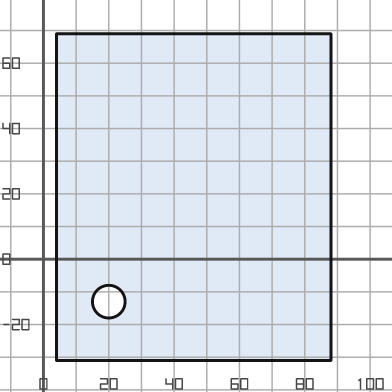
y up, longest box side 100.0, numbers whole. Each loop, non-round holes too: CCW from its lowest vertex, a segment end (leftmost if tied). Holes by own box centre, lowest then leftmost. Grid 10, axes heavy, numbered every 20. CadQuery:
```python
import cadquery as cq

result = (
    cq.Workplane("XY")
    .moveTo(4.0, -31.0)
    .lineTo(88.0, -31.0)
    .lineTo(88.0, 69.0)
    .lineTo(4.0, 69.0)
    .close()
    .moveTo(20.0, -13.0)
    .circle(5.0)
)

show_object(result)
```